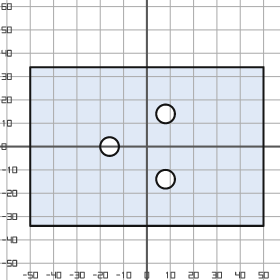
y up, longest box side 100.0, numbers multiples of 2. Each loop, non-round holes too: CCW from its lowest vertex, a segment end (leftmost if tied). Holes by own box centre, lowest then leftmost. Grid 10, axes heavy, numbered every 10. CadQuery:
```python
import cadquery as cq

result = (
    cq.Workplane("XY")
    .moveTo(-50.0, -34.0)
    .lineTo(50.0, -34.0)
    .lineTo(50.0, 34.0)
    .lineTo(-50.0, 34.0)
    .close()
    .moveTo(8.0, -14.0)
    .circle(4.0)
    .moveTo(-16.0, 0.0)
    .circle(4.0)
    .moveTo(8.0, 14.0)
    .circle(4.0)
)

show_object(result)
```